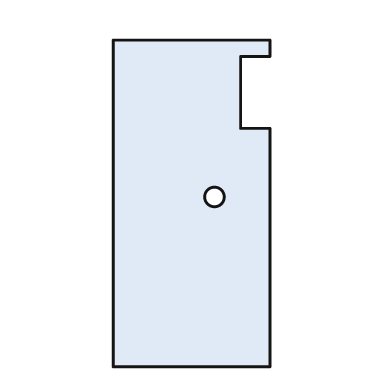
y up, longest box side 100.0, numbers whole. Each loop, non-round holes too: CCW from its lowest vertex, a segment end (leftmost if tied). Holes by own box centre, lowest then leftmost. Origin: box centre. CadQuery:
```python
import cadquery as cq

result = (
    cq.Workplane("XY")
    .moveTo(-24.0, -50.0)
    .lineTo(24.0, -50.0)
    .lineTo(24.0, 23.0)
    .lineTo(15.0, 23.0)
    .lineTo(15.0, 45.0)
    .lineTo(24.0, 45.0)
    .lineTo(24.0, 50.0)
    .lineTo(-24.0, 50.0)
    .close()
    .moveTo(7.0, 2.0)
    .circle(3.0)
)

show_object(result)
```